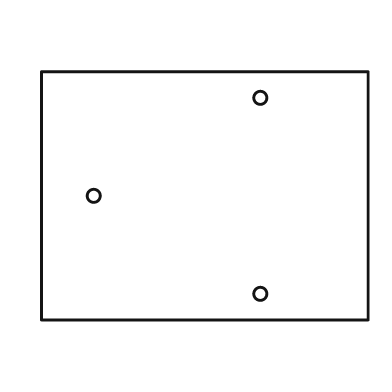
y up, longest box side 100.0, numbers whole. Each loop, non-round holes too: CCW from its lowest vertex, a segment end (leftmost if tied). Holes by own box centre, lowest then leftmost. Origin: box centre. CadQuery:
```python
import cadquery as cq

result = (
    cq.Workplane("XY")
    .moveTo(-50.0, -38.0)
    .lineTo(50.0, -38.0)
    .lineTo(50.0, 38.0)
    .lineTo(-50.0, 38.0)
    .close()
    .moveTo(17.0, -30.0)
    .circle(2.0)
    .moveTo(-34.0, 0.0)
    .circle(2.0)
    .moveTo(17.0, 30.0)
    .circle(2.0)
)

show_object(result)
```